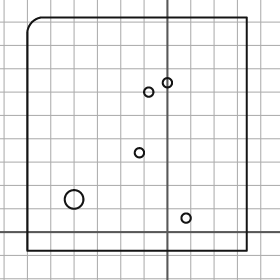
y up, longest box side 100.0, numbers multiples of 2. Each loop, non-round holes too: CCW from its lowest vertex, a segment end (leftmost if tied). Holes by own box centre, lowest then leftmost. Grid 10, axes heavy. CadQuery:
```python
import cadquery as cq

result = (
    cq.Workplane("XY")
    .moveTo(-60.0, -8.0)
    .lineTo(34.0, -8.0)
    .lineTo(34.0, 92.0)
    .lineTo(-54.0, 92.0)
    .threePointArc((-58.0, 90.0), (-60.0, 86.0))
    .close()
    .moveTo(8.0, 6.0)
    .circle(2.0)
    .moveTo(-40.0, 14.0)
    .circle(4.0)
    .moveTo(-12.0, 34.0)
    .circle(2.0)
    .moveTo(-8.0, 60.0)
    .circle(2.0)
    .moveTo(0.0, 64.0)
    .circle(2.0)
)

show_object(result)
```